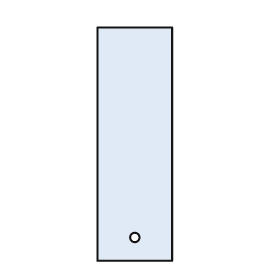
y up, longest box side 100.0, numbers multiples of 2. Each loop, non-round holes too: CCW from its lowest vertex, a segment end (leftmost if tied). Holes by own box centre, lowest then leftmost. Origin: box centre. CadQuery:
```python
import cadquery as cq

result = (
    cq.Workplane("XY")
    .moveTo(-16.0, -50.0)
    .lineTo(16.0, -50.0)
    .lineTo(16.0, 50.0)
    .lineTo(-16.0, 50.0)
    .close()
    .moveTo(0.0, -40.0)
    .circle(2.0)
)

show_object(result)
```